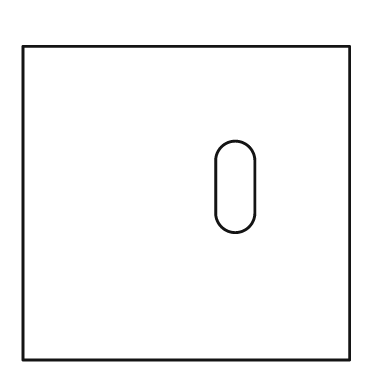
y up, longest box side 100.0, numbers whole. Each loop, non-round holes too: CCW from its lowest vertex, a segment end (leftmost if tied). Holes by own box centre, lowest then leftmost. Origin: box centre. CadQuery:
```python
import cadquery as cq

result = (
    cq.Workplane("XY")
    .moveTo(-50.0, -48.0)
    .lineTo(50.0, -48.0)
    .lineTo(50.0, 48.0)
    .lineTo(-50.0, 48.0)
    .close()
    .moveTo(9.0, -3.0)
    .threePointArc((15.0, -9.0), (21.0, -3.0))
    .lineTo(21.0, 13.0)
    .threePointArc((15.0, 19.0), (9.0, 13.0))
    .close()
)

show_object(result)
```